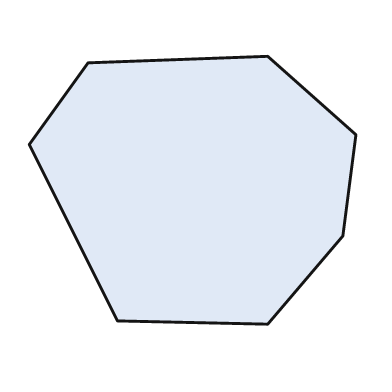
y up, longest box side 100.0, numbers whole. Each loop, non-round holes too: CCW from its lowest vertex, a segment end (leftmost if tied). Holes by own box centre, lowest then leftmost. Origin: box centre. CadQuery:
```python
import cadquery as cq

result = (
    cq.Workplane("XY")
    .moveTo(23.0, -41.0)
    .lineTo(46.0, -14.0)
    .lineTo(50.0, 17.0)
    .lineTo(23.0, 41.0)
    .lineTo(-32.0, 39.0)
    .lineTo(-50.0, 14.0)
    .lineTo(-23.0, -40.0)
    .close()
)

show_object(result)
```